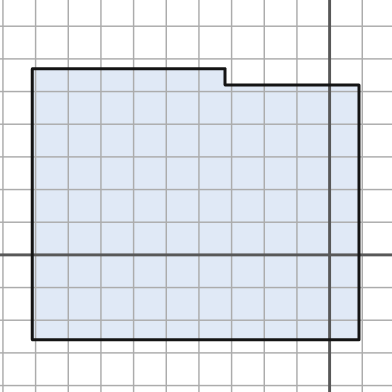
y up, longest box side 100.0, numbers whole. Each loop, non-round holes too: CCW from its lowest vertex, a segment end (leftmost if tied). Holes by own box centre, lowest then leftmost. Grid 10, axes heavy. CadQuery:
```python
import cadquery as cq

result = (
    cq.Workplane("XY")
    .moveTo(-91.0, -26.0)
    .lineTo(9.0, -26.0)
    .lineTo(9.0, 52.0)
    .lineTo(-32.0, 52.0)
    .lineTo(-32.0, 57.0)
    .lineTo(-91.0, 57.0)
    .close()
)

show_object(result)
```